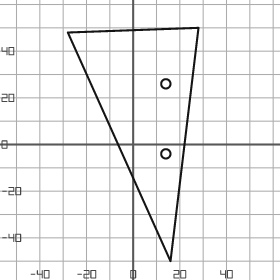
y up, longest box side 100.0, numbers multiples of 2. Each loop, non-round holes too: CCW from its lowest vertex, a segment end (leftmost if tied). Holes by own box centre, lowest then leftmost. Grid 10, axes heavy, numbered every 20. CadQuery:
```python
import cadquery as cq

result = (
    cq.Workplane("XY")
    .moveTo(16.0, -50.0)
    .lineTo(28.0, 50.0)
    .lineTo(-28.0, 48.0)
    .close()
    .moveTo(14.0, -4.0)
    .circle(2.0)
    .moveTo(14.0, 26.0)
    .circle(2.0)
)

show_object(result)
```